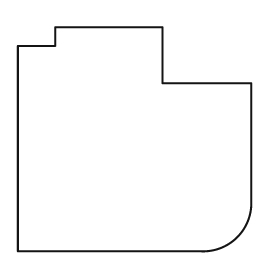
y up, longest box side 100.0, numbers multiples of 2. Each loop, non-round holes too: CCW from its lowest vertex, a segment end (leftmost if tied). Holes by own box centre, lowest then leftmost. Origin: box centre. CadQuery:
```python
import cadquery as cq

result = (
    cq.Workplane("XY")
    .moveTo(-50.0, -48.0)
    .lineTo(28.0, -48.0)
    .threePointArc((44.0, -42.0), (50.0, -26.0))
    .lineTo(50.0, 24.0)
    .lineTo(12.0, 24.0)
    .lineTo(12.0, 48.0)
    .lineTo(-34.0, 48.0)
    .lineTo(-34.0, 40.0)
    .lineTo(-50.0, 40.0)
    .close()
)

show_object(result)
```